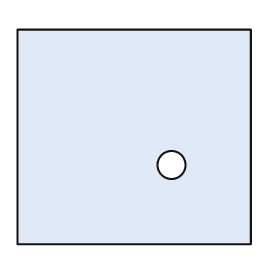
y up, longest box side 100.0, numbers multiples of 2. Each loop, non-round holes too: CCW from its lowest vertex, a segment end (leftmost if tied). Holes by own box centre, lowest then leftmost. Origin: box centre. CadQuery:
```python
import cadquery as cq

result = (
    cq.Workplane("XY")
    .moveTo(-50.0, -46.0)
    .lineTo(50.0, -46.0)
    .lineTo(50.0, 46.0)
    .lineTo(-50.0, 46.0)
    .close()
    .moveTo(16.0, -12.0)
    .circle(6.0)
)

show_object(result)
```